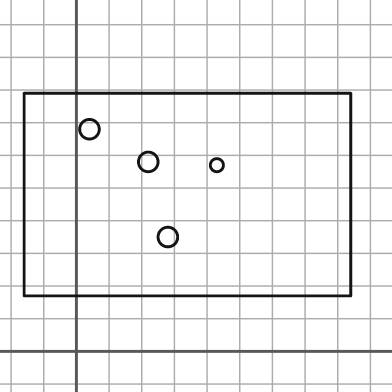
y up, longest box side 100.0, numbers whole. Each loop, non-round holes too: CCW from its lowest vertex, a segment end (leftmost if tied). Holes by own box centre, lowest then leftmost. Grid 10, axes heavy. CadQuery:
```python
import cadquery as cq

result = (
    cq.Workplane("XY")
    .moveTo(-16.0, 17.0)
    .lineTo(84.0, 17.0)
    .lineTo(84.0, 79.0)
    .lineTo(-16.0, 79.0)
    .close()
    .moveTo(28.0, 35.0)
    .circle(3.0)
    .moveTo(43.0, 57.0)
    .circle(2.0)
    .moveTo(22.0, 58.0)
    .circle(3.0)
    .moveTo(4.0, 68.0)
    .circle(3.0)
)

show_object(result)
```